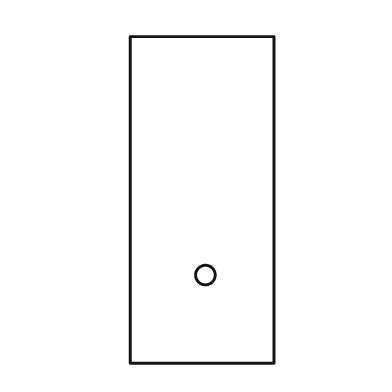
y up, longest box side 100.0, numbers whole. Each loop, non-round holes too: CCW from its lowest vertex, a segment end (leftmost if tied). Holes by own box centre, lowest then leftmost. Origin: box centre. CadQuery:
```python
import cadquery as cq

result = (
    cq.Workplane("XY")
    .moveTo(-22.0, -50.0)
    .lineTo(22.0, -50.0)
    .lineTo(22.0, 50.0)
    .lineTo(-22.0, 50.0)
    .close()
    .moveTo(1.0, -23.0)
    .circle(3.0)
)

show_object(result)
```